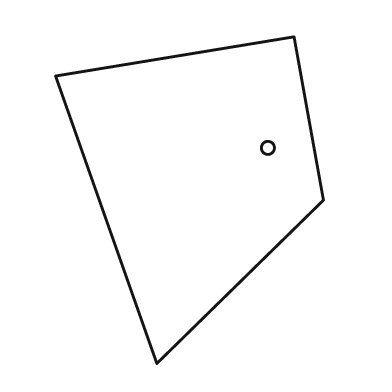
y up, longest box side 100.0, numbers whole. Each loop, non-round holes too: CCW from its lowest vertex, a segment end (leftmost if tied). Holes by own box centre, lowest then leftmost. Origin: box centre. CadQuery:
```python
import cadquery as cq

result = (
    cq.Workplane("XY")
    .moveTo(-10.0, -50.0)
    .lineTo(41.0, 0.0)
    .lineTo(32.0, 50.0)
    .lineTo(-41.0, 38.0)
    .close()
    .moveTo(24.0, 16.0)
    .circle(2.0)
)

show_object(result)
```